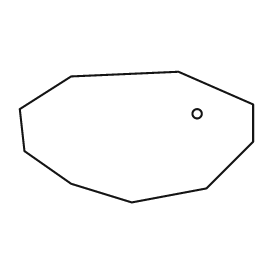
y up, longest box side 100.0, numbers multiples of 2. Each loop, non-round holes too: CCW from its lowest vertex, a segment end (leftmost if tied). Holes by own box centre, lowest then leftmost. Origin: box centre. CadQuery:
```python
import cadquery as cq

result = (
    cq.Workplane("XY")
    .moveTo(-2.0, -28.0)
    .lineTo(30.0, -22.0)
    .lineTo(50.0, -2.0)
    .lineTo(50.0, 14.0)
    .lineTo(18.0, 28.0)
    .lineTo(-28.0, 26.0)
    .lineTo(-50.0, 12.0)
    .lineTo(-48.0, -6.0)
    .lineTo(-28.0, -20.0)
    .close()
    .moveTo(26.0, 10.0)
    .circle(2.0)
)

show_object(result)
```